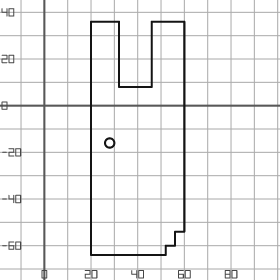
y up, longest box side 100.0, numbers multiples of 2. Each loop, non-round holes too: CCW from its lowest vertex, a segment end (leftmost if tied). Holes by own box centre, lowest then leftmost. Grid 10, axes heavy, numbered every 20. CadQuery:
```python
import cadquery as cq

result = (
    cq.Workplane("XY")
    .moveTo(20.0, -64.0)
    .lineTo(52.0, -64.0)
    .lineTo(52.0, -60.0)
    .lineTo(56.0, -60.0)
    .lineTo(56.0, -54.0)
    .lineTo(60.0, -54.0)
    .lineTo(60.0, 36.0)
    .lineTo(46.0, 36.0)
    .lineTo(46.0, 8.0)
    .lineTo(32.0, 8.0)
    .lineTo(32.0, 36.0)
    .lineTo(20.0, 36.0)
    .close()
    .moveTo(28.0, -16.0)
    .circle(2.0)
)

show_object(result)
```